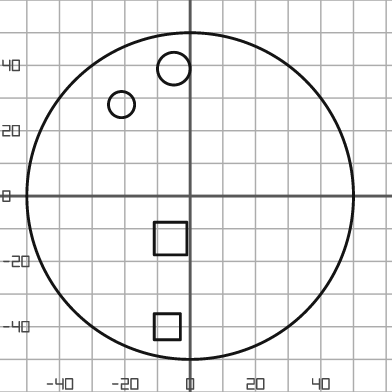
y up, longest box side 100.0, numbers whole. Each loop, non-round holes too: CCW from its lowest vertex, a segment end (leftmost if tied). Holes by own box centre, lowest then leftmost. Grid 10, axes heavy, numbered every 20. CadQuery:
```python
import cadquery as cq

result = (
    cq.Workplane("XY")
    .moveTo(0.0, 0.0)
    .circle(50.0)
    .moveTo(-11.0, -44.0)
    .lineTo(-3.0, -44.0)
    .lineTo(-3.0, -36.0)
    .lineTo(-11.0, -36.0)
    .close()
    .moveTo(-11.0, -18.0)
    .lineTo(-1.0, -18.0)
    .lineTo(-1.0, -8.0)
    .lineTo(-11.0, -8.0)
    .close()
    .moveTo(-21.0, 28.0)
    .circle(4.0)
    .moveTo(-5.0, 39.0)
    .circle(5.0)
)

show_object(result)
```